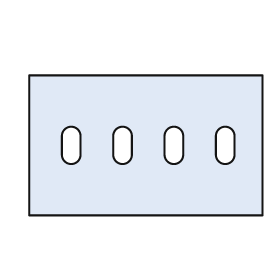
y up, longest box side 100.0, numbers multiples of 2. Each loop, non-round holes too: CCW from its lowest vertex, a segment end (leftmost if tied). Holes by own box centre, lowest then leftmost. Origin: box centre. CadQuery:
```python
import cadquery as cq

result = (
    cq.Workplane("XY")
    .moveTo(-50.0, -30.0)
    .lineTo(50.0, -30.0)
    .lineTo(50.0, 30.0)
    .lineTo(-50.0, 30.0)
    .close()
    .moveTo(-36.0, -4.0)
    .threePointArc((-32.0, -8.0), (-28.0, -4.0))
    .lineTo(-28.0, 4.0)
    .threePointArc((-32.0, 8.0), (-36.0, 4.0))
    .close()
    .moveTo(-14.0, -4.0)
    .threePointArc((-10.0, -8.0), (-6.0, -4.0))
    .lineTo(-6.0, 4.0)
    .threePointArc((-10.0, 8.0), (-14.0, 4.0))
    .close()
    .moveTo(8.0, -4.0)
    .threePointArc((12.0, -8.0), (16.0, -4.0))
    .lineTo(16.0, 4.0)
    .threePointArc((12.0, 8.0), (8.0, 4.0))
    .close()
    .moveTo(30.0, -4.0)
    .threePointArc((34.0, -8.0), (38.0, -4.0))
    .lineTo(38.0, 4.0)
    .threePointArc((34.0, 8.0), (30.0, 4.0))
    .close()
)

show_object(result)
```